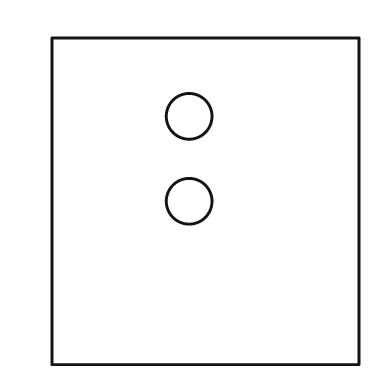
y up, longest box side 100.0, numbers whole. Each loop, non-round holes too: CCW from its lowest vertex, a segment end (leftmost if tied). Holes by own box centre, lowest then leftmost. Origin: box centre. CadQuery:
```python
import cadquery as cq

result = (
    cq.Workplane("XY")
    .moveTo(-47.0, -50.0)
    .lineTo(47.0, -50.0)
    .lineTo(47.0, 50.0)
    .lineTo(-47.0, 50.0)
    .close()
    .moveTo(-5.0, 0.0)
    .circle(7.0)
    .moveTo(-5.0, 26.0)
    .circle(7.0)
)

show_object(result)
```